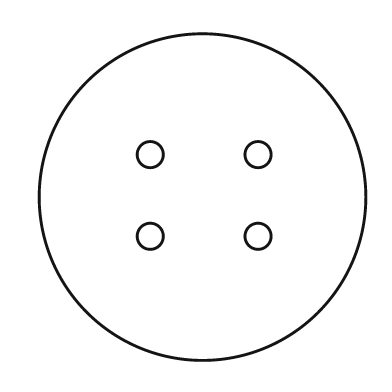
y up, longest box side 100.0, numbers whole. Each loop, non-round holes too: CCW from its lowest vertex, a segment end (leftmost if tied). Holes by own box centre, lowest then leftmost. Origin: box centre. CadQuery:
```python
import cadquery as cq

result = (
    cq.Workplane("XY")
    .moveTo(0.0, 0.0)
    .circle(50.0)
    .moveTo(-16.0, -12.0)
    .circle(4.0)
    .moveTo(17.0, -12.0)
    .circle(4.0)
    .moveTo(-16.0, 13.0)
    .circle(4.0)
    .moveTo(17.0, 13.0)
    .circle(4.0)
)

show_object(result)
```